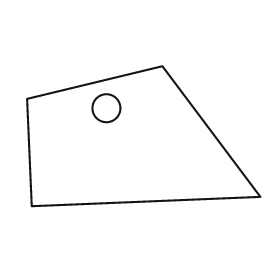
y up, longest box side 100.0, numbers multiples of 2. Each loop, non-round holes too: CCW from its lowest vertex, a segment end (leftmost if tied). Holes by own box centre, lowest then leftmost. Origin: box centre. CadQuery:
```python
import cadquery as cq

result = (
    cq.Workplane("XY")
    .moveTo(-48.0, -30.0)
    .lineTo(50.0, -26.0)
    .lineTo(8.0, 30.0)
    .lineTo(-50.0, 16.0)
    .close()
    .moveTo(-16.0, 12.0)
    .circle(6.0)
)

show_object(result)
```